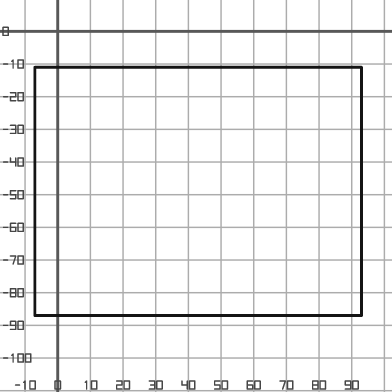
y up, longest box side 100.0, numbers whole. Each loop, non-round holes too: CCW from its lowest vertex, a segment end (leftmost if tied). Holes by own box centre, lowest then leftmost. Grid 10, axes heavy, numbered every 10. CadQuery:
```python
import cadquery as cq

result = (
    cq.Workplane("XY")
    .moveTo(-7.0, -87.0)
    .lineTo(93.0, -87.0)
    .lineTo(93.0, -11.0)
    .lineTo(-7.0, -11.0)
    .close()
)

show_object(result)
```